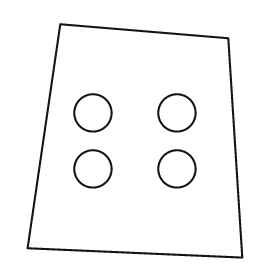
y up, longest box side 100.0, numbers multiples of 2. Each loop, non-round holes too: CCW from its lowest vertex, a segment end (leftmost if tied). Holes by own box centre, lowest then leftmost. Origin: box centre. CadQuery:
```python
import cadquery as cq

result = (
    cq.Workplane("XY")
    .moveTo(46.0, -50.0)
    .lineTo(40.0, 44.0)
    .lineTo(-32.0, 50.0)
    .lineTo(-46.0, -46.0)
    .close()
    .moveTo(-18.0, -12.0)
    .circle(8.0)
    .moveTo(18.0, -12.0)
    .circle(8.0)
    .moveTo(-18.0, 12.0)
    .circle(8.0)
    .moveTo(18.0, 12.0)
    .circle(8.0)
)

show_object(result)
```